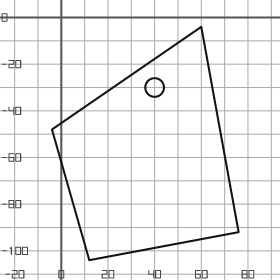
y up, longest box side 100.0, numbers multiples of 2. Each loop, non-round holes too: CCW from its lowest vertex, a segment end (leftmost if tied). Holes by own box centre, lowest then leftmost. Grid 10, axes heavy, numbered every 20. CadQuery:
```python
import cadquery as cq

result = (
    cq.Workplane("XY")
    .moveTo(12.0, -104.0)
    .lineTo(76.0, -92.0)
    .lineTo(60.0, -4.0)
    .lineTo(-4.0, -48.0)
    .close()
    .moveTo(40.0, -30.0)
    .circle(4.0)
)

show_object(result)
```